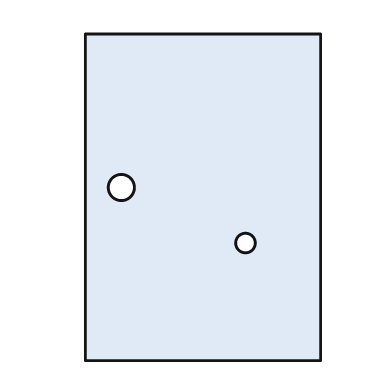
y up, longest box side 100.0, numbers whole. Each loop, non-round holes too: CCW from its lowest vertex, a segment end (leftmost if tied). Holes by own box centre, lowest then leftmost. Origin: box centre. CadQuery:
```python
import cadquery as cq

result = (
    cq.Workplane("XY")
    .moveTo(-36.0, -50.0)
    .lineTo(36.0, -50.0)
    .lineTo(36.0, 50.0)
    .lineTo(-36.0, 50.0)
    .close()
    .moveTo(13.0, -14.0)
    .circle(3.0)
    .moveTo(-25.0, 3.0)
    .circle(4.0)
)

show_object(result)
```